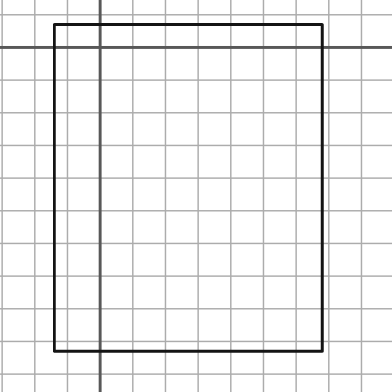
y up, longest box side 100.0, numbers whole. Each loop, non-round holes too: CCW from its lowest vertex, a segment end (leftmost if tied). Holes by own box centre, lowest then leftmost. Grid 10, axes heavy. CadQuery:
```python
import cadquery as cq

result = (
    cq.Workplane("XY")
    .moveTo(-14.0, -93.0)
    .lineTo(68.0, -93.0)
    .lineTo(68.0, 7.0)
    .lineTo(-14.0, 7.0)
    .close()
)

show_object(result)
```